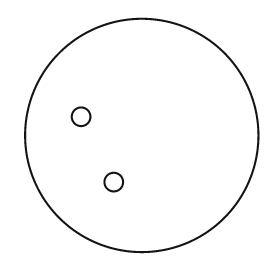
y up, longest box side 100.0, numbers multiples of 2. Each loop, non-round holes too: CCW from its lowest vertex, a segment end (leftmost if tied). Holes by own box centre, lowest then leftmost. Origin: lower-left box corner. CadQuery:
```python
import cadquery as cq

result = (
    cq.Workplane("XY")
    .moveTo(50.0, 50.0)
    .circle(50.0)
    .moveTo(38.0, 30.0)
    .circle(4.0)
    .moveTo(24.0, 58.0)
    .circle(4.0)
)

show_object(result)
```